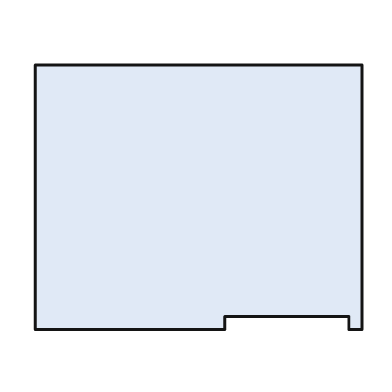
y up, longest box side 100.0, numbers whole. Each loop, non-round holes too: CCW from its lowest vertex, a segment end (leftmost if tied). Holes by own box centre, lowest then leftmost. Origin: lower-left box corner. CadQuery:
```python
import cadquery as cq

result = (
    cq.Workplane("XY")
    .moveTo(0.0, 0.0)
    .lineTo(58.0, 0.0)
    .lineTo(58.0, 4.0)
    .lineTo(96.0, 4.0)
    .lineTo(96.0, 0.0)
    .lineTo(100.0, 0.0)
    .lineTo(100.0, 81.0)
    .lineTo(0.0, 81.0)
    .close()
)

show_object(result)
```